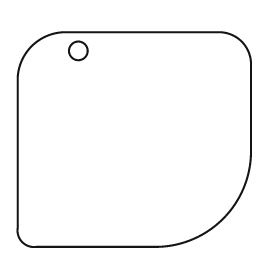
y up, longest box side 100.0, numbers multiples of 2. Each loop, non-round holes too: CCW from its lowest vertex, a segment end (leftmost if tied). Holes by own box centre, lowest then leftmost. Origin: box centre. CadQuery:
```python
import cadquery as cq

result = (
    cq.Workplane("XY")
    .moveTo(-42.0, -46.0)
    .lineTo(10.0, -46.0)
    .threePointArc((38.0, -34.0), (50.0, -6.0))
    .lineTo(50.0, 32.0)
    .threePointArc((46.0, 42.0), (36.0, 46.0))
    .lineTo(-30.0, 46.0)
    .threePointArc((-44.0, 40.0), (-50.0, 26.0))
    .lineTo(-50.0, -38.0)
    .threePointArc((-48.0, -44.0), (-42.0, -46.0))
    .close()
    .moveTo(-24.0, 38.0)
    .circle(4.0)
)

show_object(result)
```